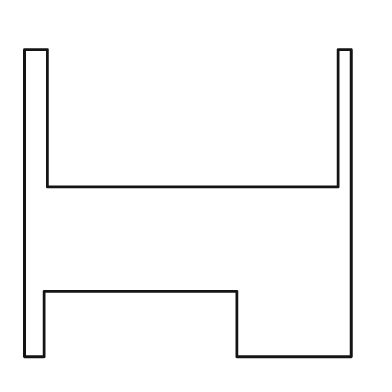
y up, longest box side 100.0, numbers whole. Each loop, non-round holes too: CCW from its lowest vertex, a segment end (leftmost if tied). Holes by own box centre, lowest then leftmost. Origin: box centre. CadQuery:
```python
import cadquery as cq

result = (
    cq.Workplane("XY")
    .moveTo(-50.0, -47.0)
    .lineTo(-44.0, -47.0)
    .lineTo(-44.0, -27.0)
    .lineTo(15.0, -27.0)
    .lineTo(15.0, -47.0)
    .lineTo(50.0, -47.0)
    .lineTo(50.0, 47.0)
    .lineTo(46.0, 47.0)
    .lineTo(46.0, 5.0)
    .lineTo(-43.0, 5.0)
    .lineTo(-43.0, 47.0)
    .lineTo(-50.0, 47.0)
    .close()
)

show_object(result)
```